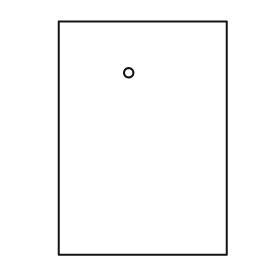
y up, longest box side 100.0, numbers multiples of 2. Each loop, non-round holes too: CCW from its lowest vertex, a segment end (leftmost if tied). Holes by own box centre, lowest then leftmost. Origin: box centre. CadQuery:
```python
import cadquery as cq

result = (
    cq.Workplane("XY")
    .moveTo(-36.0, -50.0)
    .lineTo(36.0, -50.0)
    .lineTo(36.0, 50.0)
    .lineTo(-36.0, 50.0)
    .close()
    .moveTo(-6.0, 28.0)
    .circle(2.0)
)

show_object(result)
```